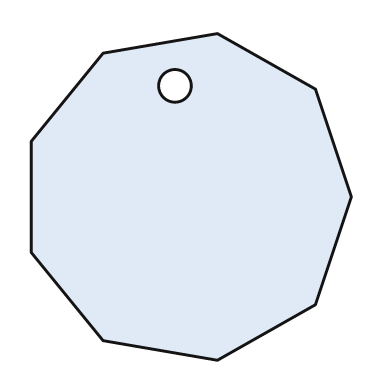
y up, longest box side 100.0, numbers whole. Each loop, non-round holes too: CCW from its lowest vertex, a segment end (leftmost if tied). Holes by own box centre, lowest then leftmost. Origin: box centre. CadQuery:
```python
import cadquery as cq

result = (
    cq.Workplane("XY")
    .moveTo(8.0, -50.0)
    .lineTo(38.0, -33.0)
    .lineTo(49.0, 0.0)
    .lineTo(38.0, 33.0)
    .lineTo(8.0, 50.0)
    .lineTo(-27.0, 44.0)
    .lineTo(-49.0, 17.0)
    .lineTo(-49.0, -17.0)
    .lineTo(-27.0, -44.0)
    .close()
    .moveTo(-5.0, 34.0)
    .circle(5.0)
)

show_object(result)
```